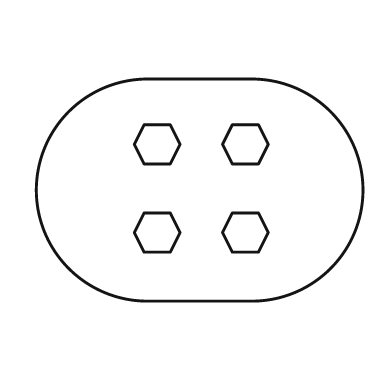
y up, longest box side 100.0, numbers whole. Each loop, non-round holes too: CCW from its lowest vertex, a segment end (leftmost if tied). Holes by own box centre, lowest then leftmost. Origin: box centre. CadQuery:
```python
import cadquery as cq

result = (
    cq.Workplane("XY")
    .moveTo(-16.0, -34.0)
    .lineTo(16.0, -34.0)
    .threePointArc((50.0, 0.0), (16.0, 34.0))
    .lineTo(-16.0, 34.0)
    .threePointArc((-50.0, 0.0), (-16.0, -34.0))
    .close()
    .moveTo(-17.0, -19.0)
    .lineTo(-9.0, -19.0)
    .lineTo(-6.0, -13.0)
    .lineTo(-9.0, -7.0)
    .lineTo(-17.0, -7.0)
    .lineTo(-20.0, -13.0)
    .close()
    .moveTo(10.0, -19.0)
    .lineTo(18.0, -19.0)
    .lineTo(21.0, -13.0)
    .lineTo(18.0, -7.0)
    .lineTo(10.0, -7.0)
    .lineTo(7.0, -13.0)
    .close()
    .moveTo(-17.0, 8.0)
    .lineTo(-9.0, 8.0)
    .lineTo(-6.0, 14.0)
    .lineTo(-9.0, 20.0)
    .lineTo(-17.0, 20.0)
    .lineTo(-20.0, 14.0)
    .close()
    .moveTo(10.0, 8.0)
    .lineTo(18.0, 8.0)
    .lineTo(21.0, 14.0)
    .lineTo(18.0, 20.0)
    .lineTo(10.0, 20.0)
    .lineTo(7.0, 14.0)
    .close()
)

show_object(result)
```